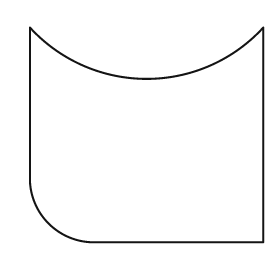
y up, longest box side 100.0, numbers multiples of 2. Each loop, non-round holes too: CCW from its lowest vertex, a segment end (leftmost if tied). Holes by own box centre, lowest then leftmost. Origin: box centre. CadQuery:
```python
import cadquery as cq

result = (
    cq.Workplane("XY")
    .moveTo(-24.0, -46.0)
    .lineTo(50.0, -46.0)
    .lineTo(50.0, 46.0)
    .threePointArc((0.0, 24.0), (-50.0, 46.0))
    .lineTo(-50.0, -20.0)
    .threePointArc((-42.0, -38.0), (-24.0, -46.0))
    .close()
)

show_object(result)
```